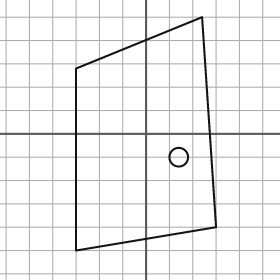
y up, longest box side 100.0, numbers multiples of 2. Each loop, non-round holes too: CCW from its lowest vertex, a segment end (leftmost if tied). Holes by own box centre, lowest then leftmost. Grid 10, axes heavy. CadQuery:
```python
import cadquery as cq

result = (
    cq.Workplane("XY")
    .moveTo(-30.0, -50.0)
    .lineTo(30.0, -40.0)
    .lineTo(24.0, 50.0)
    .lineTo(-30.0, 28.0)
    .close()
    .moveTo(14.0, -10.0)
    .circle(4.0)
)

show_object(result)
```